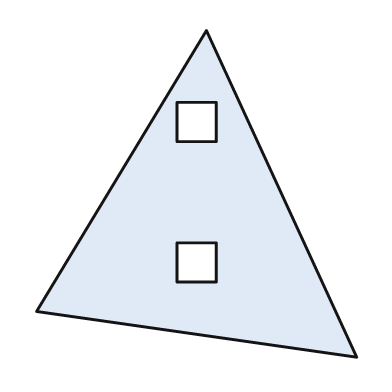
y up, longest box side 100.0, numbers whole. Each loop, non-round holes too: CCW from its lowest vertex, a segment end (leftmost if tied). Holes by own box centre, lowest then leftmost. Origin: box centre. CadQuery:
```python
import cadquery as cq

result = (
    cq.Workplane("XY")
    .moveTo(49.0, -50.0)
    .lineTo(3.0, 50.0)
    .lineTo(-49.0, -36.0)
    .close()
    .moveTo(-6.0, -27.0)
    .lineTo(6.0, -27.0)
    .lineTo(6.0, -15.0)
    .lineTo(-6.0, -15.0)
    .close()
    .moveTo(-6.0, 16.0)
    .lineTo(6.0, 16.0)
    .lineTo(6.0, 28.0)
    .lineTo(-6.0, 28.0)
    .close()
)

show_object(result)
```